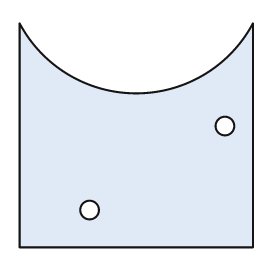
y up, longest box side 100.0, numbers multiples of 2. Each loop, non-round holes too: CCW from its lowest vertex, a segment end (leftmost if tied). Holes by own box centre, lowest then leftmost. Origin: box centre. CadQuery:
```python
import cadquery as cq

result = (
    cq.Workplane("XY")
    .moveTo(-50.0, -48.0)
    .lineTo(50.0, -48.0)
    .lineTo(50.0, 48.0)
    .threePointArc((0.0, 18.0), (-50.0, 48.0))
    .close()
    .moveTo(-20.0, -32.0)
    .circle(4.0)
    .moveTo(38.0, 4.0)
    .circle(4.0)
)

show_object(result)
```